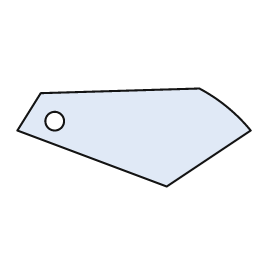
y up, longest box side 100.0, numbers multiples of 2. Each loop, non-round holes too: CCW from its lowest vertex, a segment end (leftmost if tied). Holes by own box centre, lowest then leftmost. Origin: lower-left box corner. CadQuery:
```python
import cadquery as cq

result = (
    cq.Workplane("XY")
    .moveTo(64.0, 0.0)
    .lineTo(100.0, 24.0)
    .threePointArc((90.0, 34.0), (78.0, 42.0))
    .lineTo(10.0, 40.0)
    .lineTo(0.0, 24.0)
    .close()
    .moveTo(16.0, 28.0)
    .circle(4.0)
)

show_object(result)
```